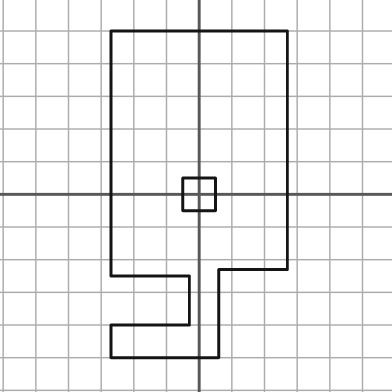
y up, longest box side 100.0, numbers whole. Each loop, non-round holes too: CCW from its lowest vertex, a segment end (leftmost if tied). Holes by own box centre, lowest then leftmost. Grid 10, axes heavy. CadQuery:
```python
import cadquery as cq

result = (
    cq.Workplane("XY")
    .moveTo(-27.0, -50.0)
    .lineTo(6.0, -50.0)
    .lineTo(6.0, -23.0)
    .lineTo(27.0, -23.0)
    .lineTo(27.0, 50.0)
    .lineTo(-27.0, 50.0)
    .lineTo(-27.0, -25.0)
    .lineTo(-3.0, -25.0)
    .lineTo(-3.0, -40.0)
    .lineTo(-27.0, -40.0)
    .close()
    .moveTo(-5.0, -5.0)
    .lineTo(5.0, -5.0)
    .lineTo(5.0, 5.0)
    .lineTo(-5.0, 5.0)
    .close()
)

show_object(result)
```